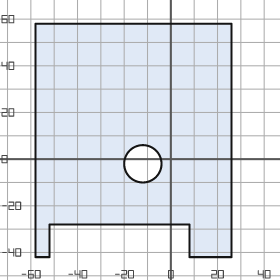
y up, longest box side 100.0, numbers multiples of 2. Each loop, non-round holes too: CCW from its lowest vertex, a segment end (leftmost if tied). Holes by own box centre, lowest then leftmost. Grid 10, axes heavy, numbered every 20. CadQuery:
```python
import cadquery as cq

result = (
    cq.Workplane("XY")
    .moveTo(-58.0, -42.0)
    .lineTo(-52.0, -42.0)
    .lineTo(-52.0, -28.0)
    .lineTo(8.0, -28.0)
    .lineTo(8.0, -42.0)
    .lineTo(26.0, -42.0)
    .lineTo(26.0, 58.0)
    .lineTo(-58.0, 58.0)
    .close()
    .moveTo(-12.0, -2.0)
    .circle(8.0)
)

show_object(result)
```